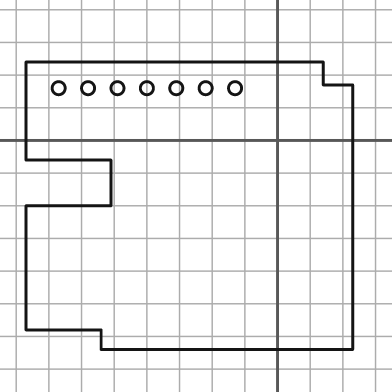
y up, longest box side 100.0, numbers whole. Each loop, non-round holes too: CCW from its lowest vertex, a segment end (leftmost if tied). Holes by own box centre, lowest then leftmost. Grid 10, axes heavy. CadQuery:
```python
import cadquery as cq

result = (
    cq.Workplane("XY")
    .moveTo(-54.0, -64.0)
    .lineTo(23.0, -64.0)
    .lineTo(23.0, 17.0)
    .lineTo(14.0, 17.0)
    .lineTo(14.0, 24.0)
    .lineTo(-77.0, 24.0)
    .lineTo(-77.0, -6.0)
    .lineTo(-51.0, -6.0)
    .lineTo(-51.0, -20.0)
    .lineTo(-77.0, -20.0)
    .lineTo(-77.0, -58.0)
    .lineTo(-54.0, -58.0)
    .close()
    .moveTo(-67.0, 16.0)
    .circle(2.0)
    .moveTo(-58.0, 16.0)
    .circle(2.0)
    .moveTo(-49.0, 16.0)
    .circle(2.0)
    .moveTo(-40.0, 16.0)
    .circle(2.0)
    .moveTo(-31.0, 16.0)
    .circle(2.0)
    .moveTo(-22.0, 16.0)
    .circle(2.0)
    .moveTo(-13.0, 16.0)
    .circle(2.0)
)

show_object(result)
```